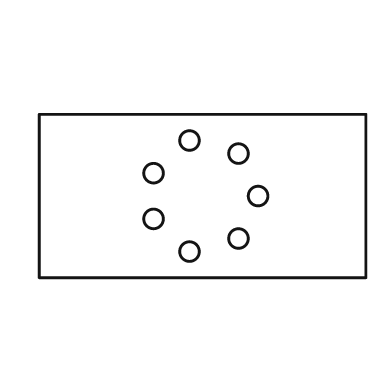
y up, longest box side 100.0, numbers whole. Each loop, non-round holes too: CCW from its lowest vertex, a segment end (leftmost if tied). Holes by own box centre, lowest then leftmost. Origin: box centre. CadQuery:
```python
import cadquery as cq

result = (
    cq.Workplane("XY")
    .moveTo(-50.0, -25.0)
    .lineTo(50.0, -25.0)
    .lineTo(50.0, 25.0)
    .lineTo(-50.0, 25.0)
    .close()
    .moveTo(-4.0, -17.0)
    .circle(3.0)
    .moveTo(11.0, -13.0)
    .circle(3.0)
    .moveTo(-15.0, -7.0)
    .circle(3.0)
    .moveTo(17.0, 0.0)
    .circle(3.0)
    .moveTo(-15.0, 7.0)
    .circle(3.0)
    .moveTo(11.0, 13.0)
    .circle(3.0)
    .moveTo(-4.0, 17.0)
    .circle(3.0)
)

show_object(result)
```